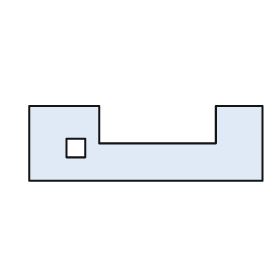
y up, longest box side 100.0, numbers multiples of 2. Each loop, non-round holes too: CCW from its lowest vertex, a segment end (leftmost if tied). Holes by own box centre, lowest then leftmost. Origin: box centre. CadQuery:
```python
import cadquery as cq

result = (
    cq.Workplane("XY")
    .moveTo(-50.0, -16.0)
    .lineTo(50.0, -16.0)
    .lineTo(50.0, 16.0)
    .lineTo(30.0, 16.0)
    .lineTo(30.0, 0.0)
    .lineTo(-20.0, 0.0)
    .lineTo(-20.0, 16.0)
    .lineTo(-50.0, 16.0)
    .close()
    .moveTo(-34.0, -6.0)
    .lineTo(-26.0, -6.0)
    .lineTo(-26.0, 2.0)
    .lineTo(-34.0, 2.0)
    .close()
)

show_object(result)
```